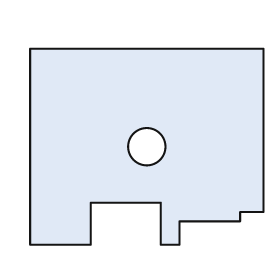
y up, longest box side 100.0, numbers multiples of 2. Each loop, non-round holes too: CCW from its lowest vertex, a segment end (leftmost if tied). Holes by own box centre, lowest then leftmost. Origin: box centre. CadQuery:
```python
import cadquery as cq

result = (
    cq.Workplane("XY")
    .moveTo(-50.0, -42.0)
    .lineTo(-24.0, -42.0)
    .lineTo(-24.0, -24.0)
    .lineTo(6.0, -24.0)
    .lineTo(6.0, -42.0)
    .lineTo(14.0, -42.0)
    .lineTo(14.0, -32.0)
    .lineTo(40.0, -32.0)
    .lineTo(40.0, -28.0)
    .lineTo(50.0, -28.0)
    .lineTo(50.0, 42.0)
    .lineTo(-50.0, 42.0)
    .close()
    .moveTo(0.0, 0.0)
    .circle(8.0)
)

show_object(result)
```